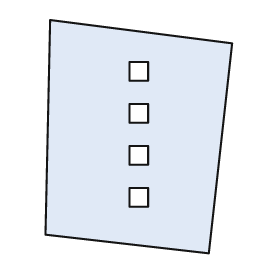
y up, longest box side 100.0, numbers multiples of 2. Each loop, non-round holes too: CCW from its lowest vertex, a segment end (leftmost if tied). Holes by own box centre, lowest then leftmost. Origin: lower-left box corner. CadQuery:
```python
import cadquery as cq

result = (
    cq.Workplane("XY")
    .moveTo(70.0, 0.0)
    .lineTo(80.0, 90.0)
    .lineTo(2.0, 100.0)
    .lineTo(0.0, 8.0)
    .close()
    .moveTo(36.0, 20.0)
    .lineTo(44.0, 20.0)
    .lineTo(44.0, 28.0)
    .lineTo(36.0, 28.0)
    .close()
    .moveTo(36.0, 38.0)
    .lineTo(44.0, 38.0)
    .lineTo(44.0, 46.0)
    .lineTo(36.0, 46.0)
    .close()
    .moveTo(36.0, 56.0)
    .lineTo(44.0, 56.0)
    .lineTo(44.0, 64.0)
    .lineTo(36.0, 64.0)
    .close()
    .moveTo(36.0, 74.0)
    .lineTo(44.0, 74.0)
    .lineTo(44.0, 82.0)
    .lineTo(36.0, 82.0)
    .close()
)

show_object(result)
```